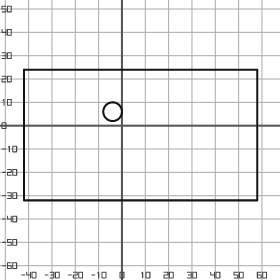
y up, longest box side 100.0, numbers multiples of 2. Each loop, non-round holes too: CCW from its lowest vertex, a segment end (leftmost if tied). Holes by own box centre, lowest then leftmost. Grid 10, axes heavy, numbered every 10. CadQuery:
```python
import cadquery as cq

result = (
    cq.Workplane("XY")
    .moveTo(-42.0, -32.0)
    .lineTo(58.0, -32.0)
    .lineTo(58.0, 24.0)
    .lineTo(-42.0, 24.0)
    .close()
    .moveTo(-4.0, 6.0)
    .circle(4.0)
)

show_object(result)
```